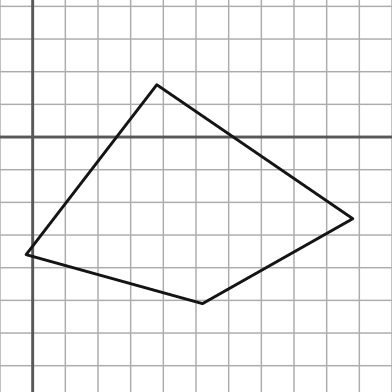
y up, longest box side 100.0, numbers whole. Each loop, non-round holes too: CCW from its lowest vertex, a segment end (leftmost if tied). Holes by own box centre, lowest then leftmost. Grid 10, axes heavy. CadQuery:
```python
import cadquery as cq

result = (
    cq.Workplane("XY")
    .moveTo(52.0, -51.0)
    .lineTo(98.0, -25.0)
    .lineTo(38.0, 16.0)
    .lineTo(-2.0, -36.0)
    .close()
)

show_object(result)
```